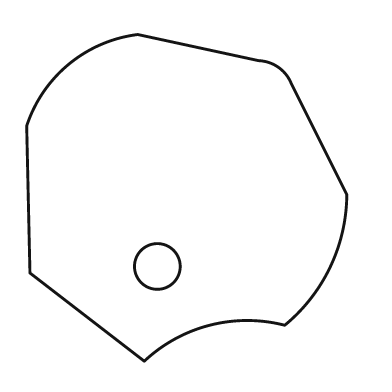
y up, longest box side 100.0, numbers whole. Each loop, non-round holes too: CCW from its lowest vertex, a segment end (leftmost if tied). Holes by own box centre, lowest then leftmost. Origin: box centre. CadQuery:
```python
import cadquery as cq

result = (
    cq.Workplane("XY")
    .moveTo(-13.0, -50.0)
    .threePointArc((7.0, -39.0), (30.0, -39.0))
    .threePointArc((44.0, -21.0), (49.0, 1.0))
    .lineTo(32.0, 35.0)
    .threePointArc((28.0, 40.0), (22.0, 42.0))
    .lineTo(-15.0, 50.0)
    .threePointArc((-36.0, 41.0), (-49.0, 22.0))
    .lineTo(-48.0, -23.0)
    .close()
    .moveTo(-9.0, -21.0)
    .circle(7.0)
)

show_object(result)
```